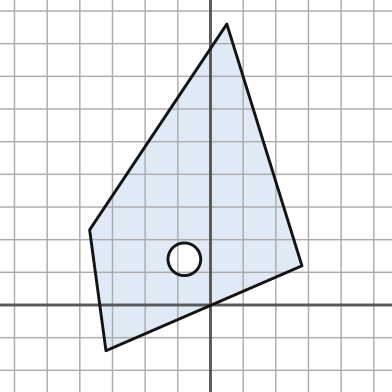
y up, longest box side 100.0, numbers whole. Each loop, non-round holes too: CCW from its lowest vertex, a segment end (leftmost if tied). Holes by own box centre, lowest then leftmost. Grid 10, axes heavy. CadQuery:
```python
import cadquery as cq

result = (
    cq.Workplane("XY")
    .moveTo(-32.0, -14.0)
    .lineTo(28.0, 12.0)
    .lineTo(5.0, 86.0)
    .lineTo(-37.0, 23.0)
    .close()
    .moveTo(-8.0, 14.0)
    .circle(5.0)
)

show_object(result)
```